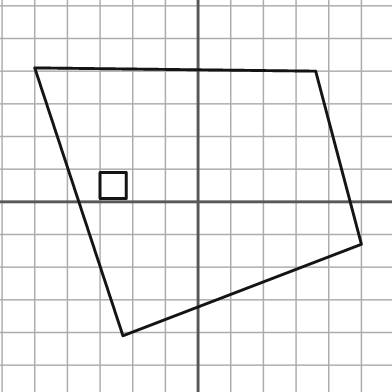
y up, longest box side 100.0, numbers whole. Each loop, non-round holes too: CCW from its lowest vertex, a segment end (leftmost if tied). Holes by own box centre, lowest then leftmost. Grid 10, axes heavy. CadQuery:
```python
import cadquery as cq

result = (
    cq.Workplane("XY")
    .moveTo(-23.0, -41.0)
    .lineTo(50.0, -13.0)
    .lineTo(36.0, 40.0)
    .lineTo(-50.0, 41.0)
    .close()
    .moveTo(-30.0, 1.0)
    .lineTo(-22.0, 1.0)
    .lineTo(-22.0, 9.0)
    .lineTo(-30.0, 9.0)
    .close()
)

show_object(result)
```